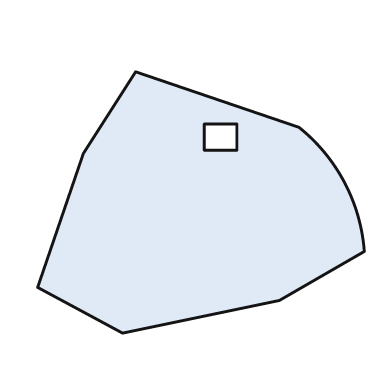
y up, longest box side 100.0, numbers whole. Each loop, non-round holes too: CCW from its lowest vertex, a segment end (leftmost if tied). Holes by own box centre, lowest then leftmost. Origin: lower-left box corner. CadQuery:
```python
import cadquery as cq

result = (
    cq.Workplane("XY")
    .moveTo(26.0, 0.0)
    .lineTo(74.0, 10.0)
    .lineTo(100.0, 25.0)
    .threePointArc((94.0, 46.0), (80.0, 63.0))
    .lineTo(30.0, 80.0)
    .lineTo(14.0, 55.0)
    .lineTo(0.0, 14.0)
    .close()
    .moveTo(51.0, 56.0)
    .lineTo(61.0, 56.0)
    .lineTo(61.0, 64.0)
    .lineTo(51.0, 64.0)
    .close()
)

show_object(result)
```